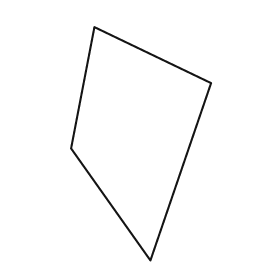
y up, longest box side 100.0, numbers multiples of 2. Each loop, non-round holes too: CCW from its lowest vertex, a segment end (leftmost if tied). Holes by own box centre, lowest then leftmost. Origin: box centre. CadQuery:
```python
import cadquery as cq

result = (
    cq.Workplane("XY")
    .moveTo(4.0, -50.0)
    .lineTo(30.0, 26.0)
    .lineTo(-20.0, 50.0)
    .lineTo(-30.0, -2.0)
    .close()
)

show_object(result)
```